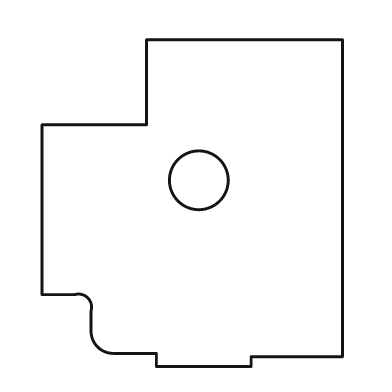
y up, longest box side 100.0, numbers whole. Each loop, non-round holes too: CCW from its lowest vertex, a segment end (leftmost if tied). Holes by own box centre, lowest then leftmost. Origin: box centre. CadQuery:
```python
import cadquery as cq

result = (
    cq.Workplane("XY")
    .moveTo(-11.0, -50.0)
    .lineTo(18.0, -50.0)
    .lineTo(18.0, -47.0)
    .lineTo(46.0, -47.0)
    .lineTo(46.0, 50.0)
    .lineTo(-14.0, 50.0)
    .lineTo(-14.0, 24.0)
    .lineTo(-46.0, 24.0)
    .lineTo(-46.0, -28.0)
    .lineTo(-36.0, -28.0)
    .threePointArc((-32.0, -29.0), (-31.0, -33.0))
    .lineTo(-31.0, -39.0)
    .threePointArc((-29.0, -44.0), (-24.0, -46.0))
    .lineTo(-11.0, -46.0)
    .close()
    .moveTo(2.0, 7.0)
    .circle(9.0)
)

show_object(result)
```